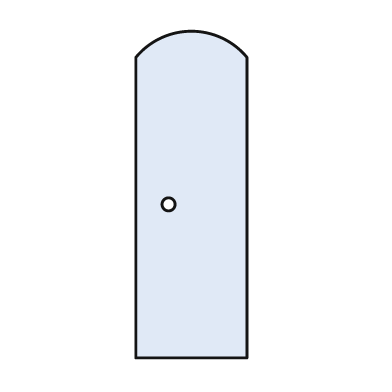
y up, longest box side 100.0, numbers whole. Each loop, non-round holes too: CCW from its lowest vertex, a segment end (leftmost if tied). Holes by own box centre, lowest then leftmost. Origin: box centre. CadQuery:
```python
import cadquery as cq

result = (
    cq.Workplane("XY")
    .moveTo(-17.0, -50.0)
    .lineTo(17.0, -50.0)
    .lineTo(17.0, 42.0)
    .threePointArc((0.0, 50.0), (-17.0, 42.0))
    .close()
    .moveTo(-7.0, -3.0)
    .circle(2.0)
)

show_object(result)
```